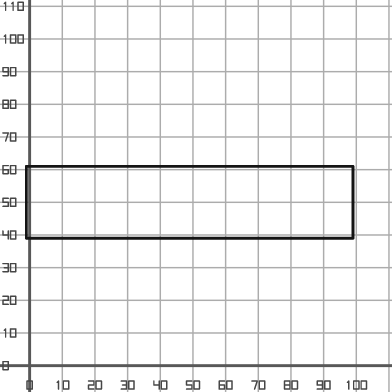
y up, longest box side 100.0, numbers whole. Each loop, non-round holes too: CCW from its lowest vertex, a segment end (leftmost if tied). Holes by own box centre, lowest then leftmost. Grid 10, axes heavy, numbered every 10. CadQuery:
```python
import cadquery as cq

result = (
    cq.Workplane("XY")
    .moveTo(-1.0, 39.0)
    .lineTo(99.0, 39.0)
    .lineTo(99.0, 61.0)
    .lineTo(-1.0, 61.0)
    .close()
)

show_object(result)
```